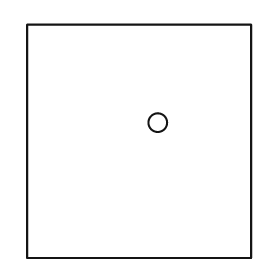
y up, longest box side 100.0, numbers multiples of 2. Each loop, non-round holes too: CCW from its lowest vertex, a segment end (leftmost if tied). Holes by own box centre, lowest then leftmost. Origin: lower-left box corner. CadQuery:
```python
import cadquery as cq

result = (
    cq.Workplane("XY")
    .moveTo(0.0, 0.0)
    .lineTo(96.0, 0.0)
    .lineTo(96.0, 100.0)
    .lineTo(0.0, 100.0)
    .close()
    .moveTo(56.0, 58.0)
    .circle(4.0)
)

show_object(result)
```